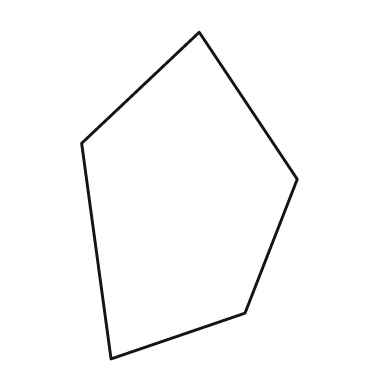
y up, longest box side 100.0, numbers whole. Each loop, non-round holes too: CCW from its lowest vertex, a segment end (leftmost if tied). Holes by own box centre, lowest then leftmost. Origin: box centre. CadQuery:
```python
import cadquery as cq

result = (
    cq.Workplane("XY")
    .moveTo(-24.0, -50.0)
    .lineTo(17.0, -36.0)
    .lineTo(33.0, 5.0)
    .lineTo(3.0, 50.0)
    .lineTo(-33.0, 16.0)
    .close()
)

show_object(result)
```